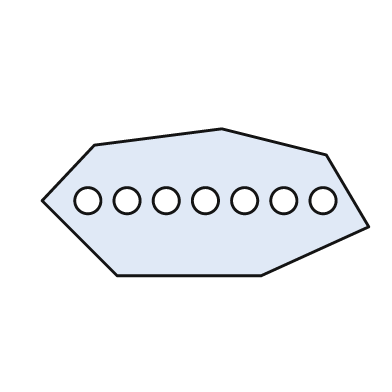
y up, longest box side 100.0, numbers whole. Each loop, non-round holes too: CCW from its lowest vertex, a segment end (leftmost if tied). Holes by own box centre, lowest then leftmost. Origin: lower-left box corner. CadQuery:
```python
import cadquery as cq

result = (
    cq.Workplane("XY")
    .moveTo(23.0, 0.0)
    .lineTo(67.0, 0.0)
    .lineTo(100.0, 15.0)
    .lineTo(87.0, 37.0)
    .lineTo(55.0, 45.0)
    .lineTo(16.0, 40.0)
    .lineTo(0.0, 23.0)
    .close()
    .moveTo(14.0, 23.0)
    .circle(4.0)
    .moveTo(26.0, 23.0)
    .circle(4.0)
    .moveTo(38.0, 23.0)
    .circle(4.0)
    .moveTo(50.0, 23.0)
    .circle(4.0)
    .moveTo(62.0, 23.0)
    .circle(4.0)
    .moveTo(74.0, 23.0)
    .circle(4.0)
    .moveTo(86.0, 23.0)
    .circle(4.0)
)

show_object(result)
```